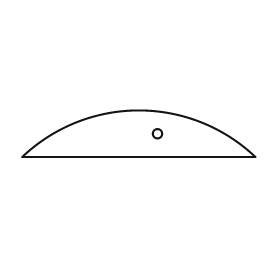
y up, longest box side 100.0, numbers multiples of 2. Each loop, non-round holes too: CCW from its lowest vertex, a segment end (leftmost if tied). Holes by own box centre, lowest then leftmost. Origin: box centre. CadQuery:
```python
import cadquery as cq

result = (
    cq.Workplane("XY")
    .moveTo(-50.0, -10.0)
    .lineTo(50.0, -10.0)
    .threePointArc((0.0, 10.0), (-50.0, -10.0))
    .close()
    .moveTo(8.0, 0.0)
    .circle(2.0)
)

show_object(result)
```